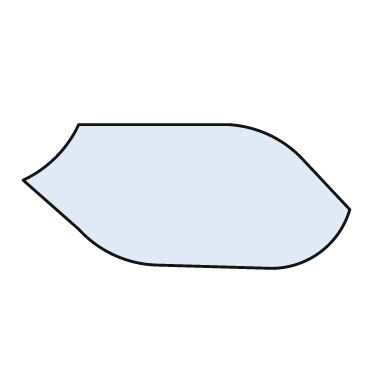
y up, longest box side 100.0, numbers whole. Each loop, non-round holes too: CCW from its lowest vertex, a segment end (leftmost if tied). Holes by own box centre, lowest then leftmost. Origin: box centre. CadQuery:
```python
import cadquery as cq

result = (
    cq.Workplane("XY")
    .moveTo(26.0, -22.0)
    .threePointArc((41.0, -17.0), (50.0, -4.0))
    .lineTo(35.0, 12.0)
    .threePointArc((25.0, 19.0), (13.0, 22.0))
    .lineTo(-33.0, 22.0)
    .threePointArc((-40.0, 12.0), (-50.0, 5.0))
    .lineTo(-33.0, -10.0)
    .threePointArc((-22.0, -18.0), (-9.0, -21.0))
    .close()
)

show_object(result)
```